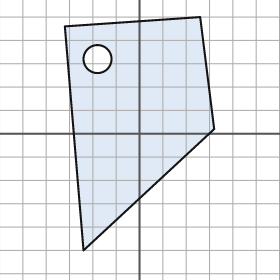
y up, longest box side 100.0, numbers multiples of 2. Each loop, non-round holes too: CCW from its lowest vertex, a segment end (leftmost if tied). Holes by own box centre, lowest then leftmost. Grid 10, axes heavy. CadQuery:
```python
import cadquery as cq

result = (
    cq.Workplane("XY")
    .moveTo(-24.0, -50.0)
    .lineTo(32.0, 2.0)
    .lineTo(26.0, 50.0)
    .lineTo(-32.0, 46.0)
    .close()
    .moveTo(-18.0, 32.0)
    .circle(6.0)
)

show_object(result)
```